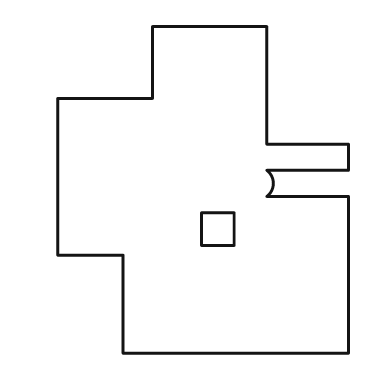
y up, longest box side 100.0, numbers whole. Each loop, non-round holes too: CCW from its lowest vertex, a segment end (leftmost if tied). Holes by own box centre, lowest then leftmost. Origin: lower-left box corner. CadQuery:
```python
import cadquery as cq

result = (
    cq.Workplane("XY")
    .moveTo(20.0, 0.0)
    .lineTo(89.0, 0.0)
    .lineTo(89.0, 48.0)
    .lineTo(64.0, 48.0)
    .threePointArc((66.0, 52.0), (64.0, 56.0))
    .lineTo(89.0, 56.0)
    .lineTo(89.0, 64.0)
    .lineTo(64.0, 64.0)
    .lineTo(64.0, 100.0)
    .lineTo(29.0, 100.0)
    .lineTo(29.0, 78.0)
    .lineTo(0.0, 78.0)
    .lineTo(0.0, 30.0)
    .lineTo(20.0, 30.0)
    .close()
    .moveTo(44.0, 33.0)
    .lineTo(54.0, 33.0)
    .lineTo(54.0, 43.0)
    .lineTo(44.0, 43.0)
    .close()
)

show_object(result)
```